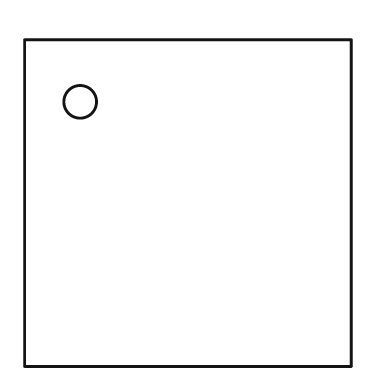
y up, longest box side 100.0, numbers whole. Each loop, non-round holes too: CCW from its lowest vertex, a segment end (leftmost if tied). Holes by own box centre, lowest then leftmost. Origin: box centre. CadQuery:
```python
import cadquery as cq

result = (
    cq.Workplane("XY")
    .moveTo(-50.0, -50.0)
    .lineTo(50.0, -50.0)
    .lineTo(50.0, 50.0)
    .lineTo(-50.0, 50.0)
    .close()
    .moveTo(-33.0, 31.0)
    .circle(5.0)
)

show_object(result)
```